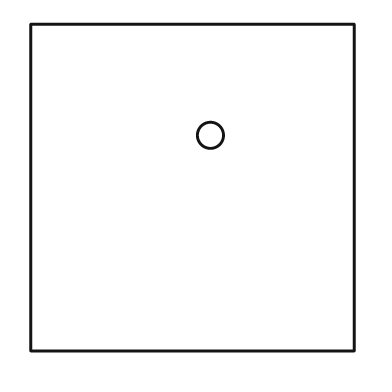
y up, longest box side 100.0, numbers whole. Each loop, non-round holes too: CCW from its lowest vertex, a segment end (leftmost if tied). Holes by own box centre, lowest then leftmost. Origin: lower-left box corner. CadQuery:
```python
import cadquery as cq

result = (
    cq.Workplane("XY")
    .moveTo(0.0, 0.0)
    .lineTo(99.0, 0.0)
    .lineTo(99.0, 100.0)
    .lineTo(0.0, 100.0)
    .close()
    .moveTo(55.0, 66.0)
    .circle(4.0)
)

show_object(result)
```